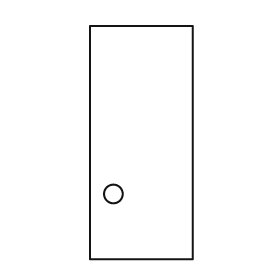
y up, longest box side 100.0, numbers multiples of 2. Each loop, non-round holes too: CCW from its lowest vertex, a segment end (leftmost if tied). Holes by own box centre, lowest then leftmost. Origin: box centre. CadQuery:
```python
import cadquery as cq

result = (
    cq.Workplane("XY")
    .moveTo(-22.0, -50.0)
    .lineTo(22.0, -50.0)
    .lineTo(22.0, 50.0)
    .lineTo(-22.0, 50.0)
    .close()
    .moveTo(-12.0, -22.0)
    .circle(4.0)
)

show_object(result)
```